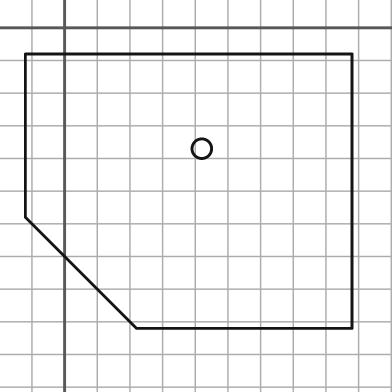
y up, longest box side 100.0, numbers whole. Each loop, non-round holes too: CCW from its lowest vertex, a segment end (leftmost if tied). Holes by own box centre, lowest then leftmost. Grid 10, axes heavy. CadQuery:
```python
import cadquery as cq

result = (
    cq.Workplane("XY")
    .moveTo(22.0, -92.0)
    .lineTo(88.0, -92.0)
    .lineTo(88.0, -8.0)
    .lineTo(-12.0, -8.0)
    .lineTo(-12.0, -58.0)
    .close()
    .moveTo(42.0, -37.0)
    .circle(3.0)
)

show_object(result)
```